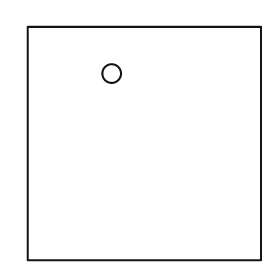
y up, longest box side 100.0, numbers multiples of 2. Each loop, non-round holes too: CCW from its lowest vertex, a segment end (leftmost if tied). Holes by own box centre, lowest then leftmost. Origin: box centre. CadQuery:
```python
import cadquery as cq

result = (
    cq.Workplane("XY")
    .moveTo(-50.0, -50.0)
    .lineTo(50.0, -50.0)
    .lineTo(50.0, 50.0)
    .lineTo(-50.0, 50.0)
    .close()
    .moveTo(-14.0, 30.0)
    .circle(4.0)
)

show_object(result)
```